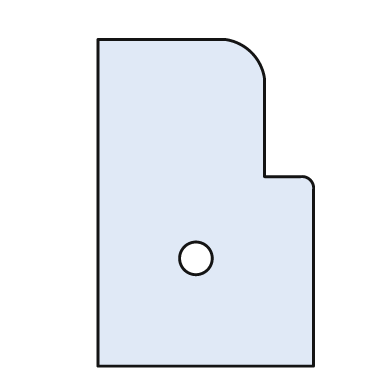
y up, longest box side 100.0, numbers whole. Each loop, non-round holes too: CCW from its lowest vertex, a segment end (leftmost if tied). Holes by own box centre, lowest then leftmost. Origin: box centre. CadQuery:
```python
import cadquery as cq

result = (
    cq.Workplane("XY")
    .moveTo(-33.0, -50.0)
    .lineTo(33.0, -50.0)
    .lineTo(33.0, 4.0)
    .threePointArc((32.0, 7.0), (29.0, 8.0))
    .lineTo(18.0, 8.0)
    .lineTo(18.0, 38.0)
    .threePointArc((14.0, 46.0), (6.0, 50.0))
    .lineTo(-33.0, 50.0)
    .close()
    .moveTo(-3.0, -17.0)
    .circle(5.0)
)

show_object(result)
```